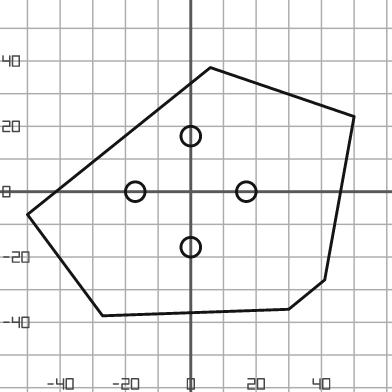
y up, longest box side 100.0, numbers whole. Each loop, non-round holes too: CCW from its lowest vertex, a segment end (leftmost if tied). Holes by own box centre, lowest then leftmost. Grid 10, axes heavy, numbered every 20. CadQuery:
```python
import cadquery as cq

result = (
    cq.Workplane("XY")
    .moveTo(-27.0, -38.0)
    .lineTo(30.0, -36.0)
    .lineTo(41.0, -27.0)
    .lineTo(50.0, 23.0)
    .lineTo(6.0, 38.0)
    .lineTo(-50.0, -7.0)
    .close()
    .moveTo(0.0, -17.0)
    .circle(3.0)
    .moveTo(-17.0, 0.0)
    .circle(3.0)
    .moveTo(17.0, 0.0)
    .circle(3.0)
    .moveTo(0.0, 17.0)
    .circle(3.0)
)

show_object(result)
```